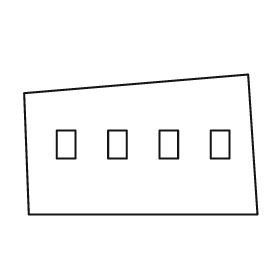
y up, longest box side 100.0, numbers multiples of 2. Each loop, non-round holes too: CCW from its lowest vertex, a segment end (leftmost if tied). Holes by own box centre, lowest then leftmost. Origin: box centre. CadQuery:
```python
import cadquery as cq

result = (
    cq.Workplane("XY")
    .moveTo(-48.0, -30.0)
    .lineTo(50.0, -30.0)
    .lineTo(46.0, 30.0)
    .lineTo(-50.0, 22.0)
    .close()
    .moveTo(-36.0, -6.0)
    .lineTo(-28.0, -6.0)
    .lineTo(-28.0, 6.0)
    .lineTo(-36.0, 6.0)
    .close()
    .moveTo(-14.0, -6.0)
    .lineTo(-6.0, -6.0)
    .lineTo(-6.0, 6.0)
    .lineTo(-14.0, 6.0)
    .close()
    .moveTo(8.0, -6.0)
    .lineTo(16.0, -6.0)
    .lineTo(16.0, 6.0)
    .lineTo(8.0, 6.0)
    .close()
    .moveTo(30.0, -6.0)
    .lineTo(38.0, -6.0)
    .lineTo(38.0, 6.0)
    .lineTo(30.0, 6.0)
    .close()
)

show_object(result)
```